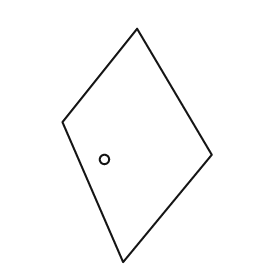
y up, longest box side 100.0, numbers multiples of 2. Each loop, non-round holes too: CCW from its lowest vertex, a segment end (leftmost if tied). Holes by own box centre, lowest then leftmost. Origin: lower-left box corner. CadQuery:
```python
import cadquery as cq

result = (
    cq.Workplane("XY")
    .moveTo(26.0, 0.0)
    .lineTo(64.0, 46.0)
    .lineTo(32.0, 100.0)
    .lineTo(0.0, 60.0)
    .close()
    .moveTo(18.0, 44.0)
    .circle(2.0)
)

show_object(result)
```